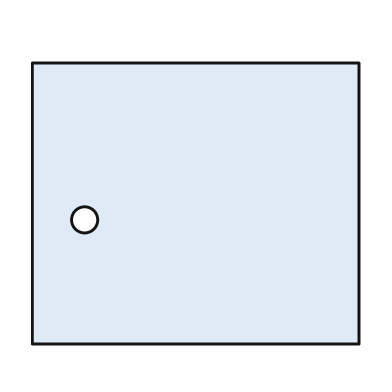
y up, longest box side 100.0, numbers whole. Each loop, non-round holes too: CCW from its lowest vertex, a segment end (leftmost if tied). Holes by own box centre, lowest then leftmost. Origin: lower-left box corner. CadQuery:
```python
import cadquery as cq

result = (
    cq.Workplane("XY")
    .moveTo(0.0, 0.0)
    .lineTo(100.0, 0.0)
    .lineTo(100.0, 86.0)
    .lineTo(0.0, 86.0)
    .close()
    .moveTo(16.0, 38.0)
    .circle(4.0)
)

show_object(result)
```